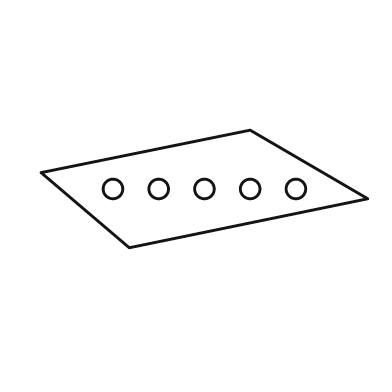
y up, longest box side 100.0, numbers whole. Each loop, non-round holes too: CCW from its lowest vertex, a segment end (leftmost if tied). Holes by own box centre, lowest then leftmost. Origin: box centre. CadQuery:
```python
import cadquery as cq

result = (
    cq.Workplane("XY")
    .moveTo(-23.0, -18.0)
    .lineTo(50.0, -3.0)
    .lineTo(14.0, 18.0)
    .lineTo(-50.0, 5.0)
    .close()
    .moveTo(-28.0, 0.0)
    .circle(3.0)
    .moveTo(-14.0, 0.0)
    .circle(3.0)
    .moveTo(0.0, 0.0)
    .circle(3.0)
    .moveTo(14.0, 0.0)
    .circle(3.0)
    .moveTo(28.0, 0.0)
    .circle(3.0)
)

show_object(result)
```